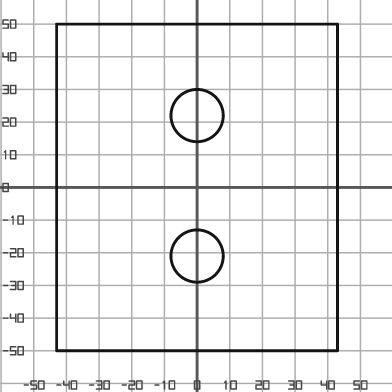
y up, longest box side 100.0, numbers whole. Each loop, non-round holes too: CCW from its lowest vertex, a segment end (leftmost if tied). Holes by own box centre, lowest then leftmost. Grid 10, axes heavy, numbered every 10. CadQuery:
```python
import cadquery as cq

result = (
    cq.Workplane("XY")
    .moveTo(-43.0, -50.0)
    .lineTo(43.0, -50.0)
    .lineTo(43.0, 50.0)
    .lineTo(-43.0, 50.0)
    .close()
    .moveTo(0.0, -21.0)
    .circle(8.0)
    .moveTo(0.0, 22.0)
    .circle(8.0)
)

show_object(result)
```